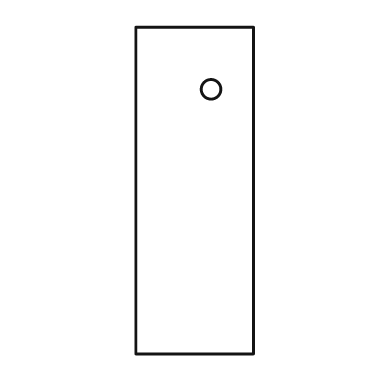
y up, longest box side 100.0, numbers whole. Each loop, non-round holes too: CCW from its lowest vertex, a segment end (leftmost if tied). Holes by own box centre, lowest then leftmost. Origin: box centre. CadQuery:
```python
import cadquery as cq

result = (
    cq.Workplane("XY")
    .moveTo(-18.0, -50.0)
    .lineTo(18.0, -50.0)
    .lineTo(18.0, 50.0)
    .lineTo(-18.0, 50.0)
    .close()
    .moveTo(5.0, 31.0)
    .circle(3.0)
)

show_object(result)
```